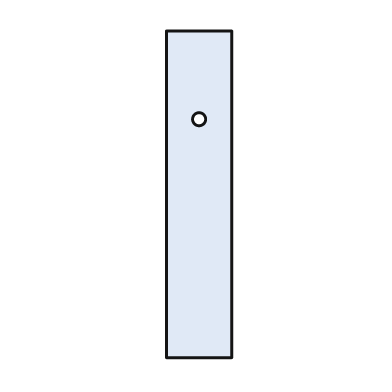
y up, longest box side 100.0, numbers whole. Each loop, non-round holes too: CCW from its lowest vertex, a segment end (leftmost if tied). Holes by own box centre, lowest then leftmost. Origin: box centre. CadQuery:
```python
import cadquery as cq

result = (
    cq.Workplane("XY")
    .moveTo(-10.0, -50.0)
    .lineTo(10.0, -50.0)
    .lineTo(10.0, 50.0)
    .lineTo(-10.0, 50.0)
    .close()
    .moveTo(0.0, 23.0)
    .circle(2.0)
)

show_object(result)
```